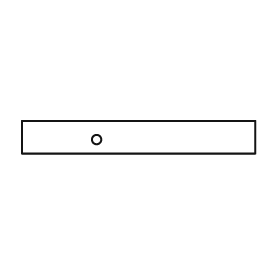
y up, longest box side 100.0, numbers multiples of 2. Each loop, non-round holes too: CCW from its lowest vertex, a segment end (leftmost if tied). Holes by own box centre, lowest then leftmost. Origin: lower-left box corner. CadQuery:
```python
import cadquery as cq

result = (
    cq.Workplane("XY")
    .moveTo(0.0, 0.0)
    .lineTo(100.0, 0.0)
    .lineTo(100.0, 14.0)
    .lineTo(0.0, 14.0)
    .close()
    .moveTo(32.0, 6.0)
    .circle(2.0)
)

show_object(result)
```